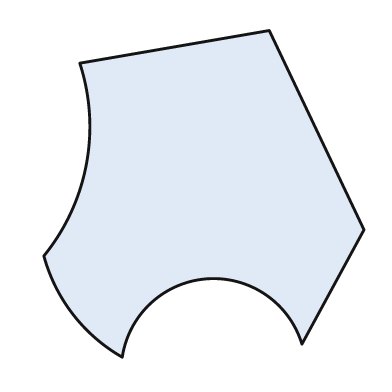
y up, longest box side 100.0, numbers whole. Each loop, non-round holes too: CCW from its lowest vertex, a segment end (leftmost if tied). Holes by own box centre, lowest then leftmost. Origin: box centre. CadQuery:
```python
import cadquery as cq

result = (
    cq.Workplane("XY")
    .moveTo(-25.0, -50.0)
    .threePointArc((1.0, -26.0), (30.0, -46.0))
    .lineTo(49.0, -11.0)
    .lineTo(20.0, 50.0)
    .lineTo(-38.0, 40.0)
    .threePointArc((-36.0, 9.0), (-49.0, -19.0))
    .threePointArc((-40.0, -37.0), (-25.0, -50.0))
    .close()
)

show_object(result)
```